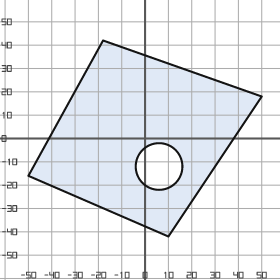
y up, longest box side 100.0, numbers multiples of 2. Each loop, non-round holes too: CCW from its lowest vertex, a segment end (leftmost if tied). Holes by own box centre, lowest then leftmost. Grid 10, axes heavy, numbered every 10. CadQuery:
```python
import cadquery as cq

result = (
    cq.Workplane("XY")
    .moveTo(10.0, -42.0)
    .lineTo(50.0, 18.0)
    .lineTo(-18.0, 42.0)
    .lineTo(-50.0, -16.0)
    .close()
    .moveTo(6.0, -12.0)
    .circle(10.0)
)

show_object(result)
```